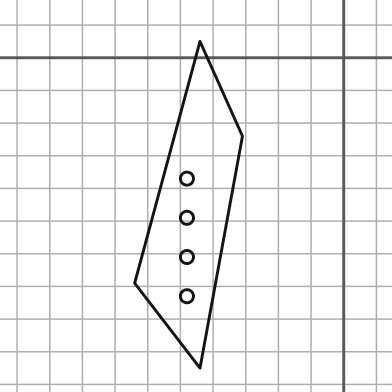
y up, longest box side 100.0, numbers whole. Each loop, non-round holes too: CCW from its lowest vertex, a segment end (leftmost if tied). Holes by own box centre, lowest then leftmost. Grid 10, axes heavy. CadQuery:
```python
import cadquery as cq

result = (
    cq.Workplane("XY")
    .moveTo(-44.0, -95.0)
    .lineTo(-31.0, -24.0)
    .lineTo(-44.0, 5.0)
    .lineTo(-64.0, -69.0)
    .close()
    .moveTo(-48.0, -73.0)
    .circle(2.0)
    .moveTo(-48.0, -61.0)
    .circle(2.0)
    .moveTo(-48.0, -49.0)
    .circle(2.0)
    .moveTo(-48.0, -37.0)
    .circle(2.0)
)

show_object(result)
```